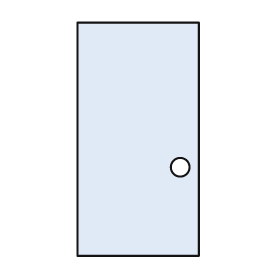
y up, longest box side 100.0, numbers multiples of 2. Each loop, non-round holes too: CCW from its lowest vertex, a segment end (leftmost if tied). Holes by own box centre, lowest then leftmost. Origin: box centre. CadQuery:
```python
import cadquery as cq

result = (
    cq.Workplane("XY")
    .moveTo(-26.0, -50.0)
    .lineTo(26.0, -50.0)
    .lineTo(26.0, 50.0)
    .lineTo(-26.0, 50.0)
    .close()
    .moveTo(18.0, -12.0)
    .circle(4.0)
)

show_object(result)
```